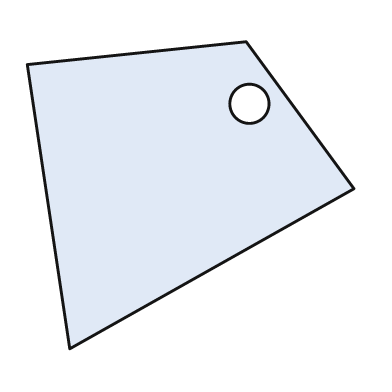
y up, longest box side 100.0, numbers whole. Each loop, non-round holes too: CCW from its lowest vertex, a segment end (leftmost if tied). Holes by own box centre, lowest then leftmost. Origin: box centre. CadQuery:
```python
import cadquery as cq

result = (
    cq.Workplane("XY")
    .moveTo(-37.0, -47.0)
    .lineTo(50.0, 2.0)
    .lineTo(17.0, 47.0)
    .lineTo(-50.0, 40.0)
    .close()
    .moveTo(18.0, 28.0)
    .circle(6.0)
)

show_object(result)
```